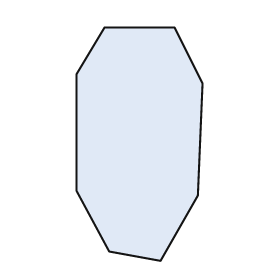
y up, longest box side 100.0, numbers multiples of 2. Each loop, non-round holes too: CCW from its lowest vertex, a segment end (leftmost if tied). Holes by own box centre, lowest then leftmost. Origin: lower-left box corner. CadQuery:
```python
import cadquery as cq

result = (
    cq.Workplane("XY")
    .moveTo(36.0, 0.0)
    .lineTo(52.0, 28.0)
    .lineTo(54.0, 76.0)
    .lineTo(42.0, 100.0)
    .lineTo(12.0, 100.0)
    .lineTo(0.0, 80.0)
    .lineTo(0.0, 30.0)
    .lineTo(14.0, 4.0)
    .close()
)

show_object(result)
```